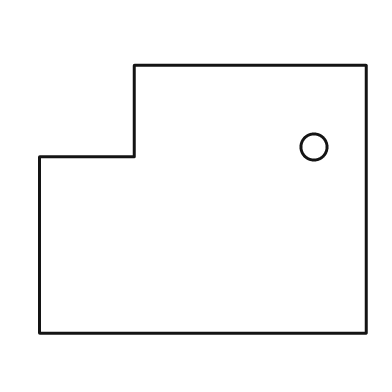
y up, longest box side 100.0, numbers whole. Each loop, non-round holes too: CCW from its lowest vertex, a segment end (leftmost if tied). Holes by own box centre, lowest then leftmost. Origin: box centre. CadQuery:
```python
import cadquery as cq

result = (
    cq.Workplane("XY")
    .moveTo(-50.0, -41.0)
    .lineTo(50.0, -41.0)
    .lineTo(50.0, 41.0)
    .lineTo(-21.0, 41.0)
    .lineTo(-21.0, 13.0)
    .lineTo(-50.0, 13.0)
    .close()
    .moveTo(34.0, 16.0)
    .circle(4.0)
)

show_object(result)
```